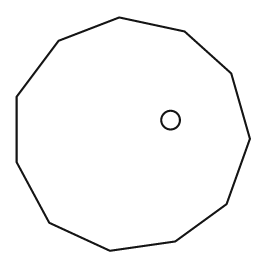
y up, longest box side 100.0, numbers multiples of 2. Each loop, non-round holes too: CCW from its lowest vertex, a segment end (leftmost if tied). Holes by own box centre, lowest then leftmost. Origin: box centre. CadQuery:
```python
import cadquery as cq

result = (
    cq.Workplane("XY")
    .moveTo(-10.0, -50.0)
    .lineTo(18.0, -46.0)
    .lineTo(40.0, -30.0)
    .lineTo(50.0, -2.0)
    .lineTo(42.0, 26.0)
    .lineTo(22.0, 44.0)
    .lineTo(-6.0, 50.0)
    .lineTo(-32.0, 40.0)
    .lineTo(-50.0, 16.0)
    .lineTo(-50.0, -12.0)
    .lineTo(-36.0, -38.0)
    .close()
    .moveTo(16.0, 6.0)
    .circle(4.0)
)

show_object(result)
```